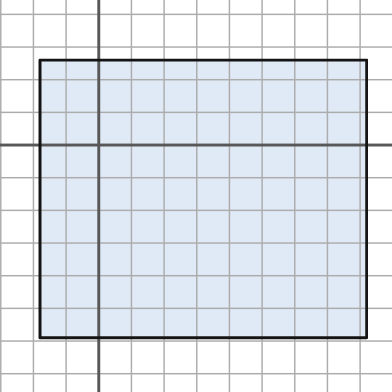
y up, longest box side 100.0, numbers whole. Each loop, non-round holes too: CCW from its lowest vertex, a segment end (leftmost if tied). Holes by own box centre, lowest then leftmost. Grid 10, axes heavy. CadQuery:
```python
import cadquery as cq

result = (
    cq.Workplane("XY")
    .moveTo(-18.0, -59.0)
    .lineTo(82.0, -59.0)
    .lineTo(82.0, 26.0)
    .lineTo(-18.0, 26.0)
    .close()
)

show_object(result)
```